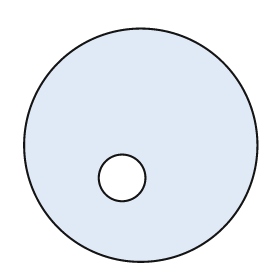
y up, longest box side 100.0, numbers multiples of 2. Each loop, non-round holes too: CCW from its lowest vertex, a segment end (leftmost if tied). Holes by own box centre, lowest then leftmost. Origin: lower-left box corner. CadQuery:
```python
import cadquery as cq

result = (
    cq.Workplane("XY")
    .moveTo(50.0, 50.0)
    .circle(50.0)
    .moveTo(42.0, 36.0)
    .circle(10.0)
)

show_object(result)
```